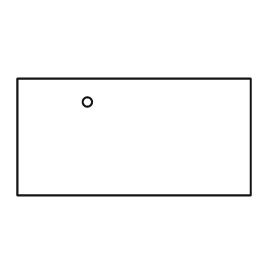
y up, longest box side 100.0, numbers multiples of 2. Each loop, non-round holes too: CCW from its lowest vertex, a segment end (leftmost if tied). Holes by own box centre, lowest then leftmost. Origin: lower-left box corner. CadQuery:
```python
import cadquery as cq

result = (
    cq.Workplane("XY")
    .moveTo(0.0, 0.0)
    .lineTo(100.0, 0.0)
    .lineTo(100.0, 50.0)
    .lineTo(0.0, 50.0)
    .close()
    .moveTo(30.0, 40.0)
    .circle(2.0)
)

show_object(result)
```